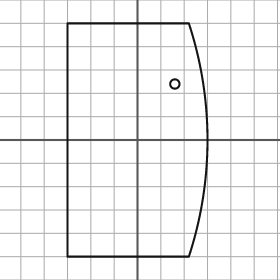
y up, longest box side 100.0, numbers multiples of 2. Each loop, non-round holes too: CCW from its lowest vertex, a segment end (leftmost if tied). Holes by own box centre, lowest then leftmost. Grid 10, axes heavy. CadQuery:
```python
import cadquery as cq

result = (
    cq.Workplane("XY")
    .moveTo(-30.0, -50.0)
    .lineTo(22.0, -50.0)
    .threePointArc((30.0, 0.0), (22.0, 50.0))
    .lineTo(-30.0, 50.0)
    .close()
    .moveTo(16.0, 24.0)
    .circle(2.0)
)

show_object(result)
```